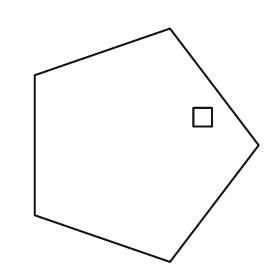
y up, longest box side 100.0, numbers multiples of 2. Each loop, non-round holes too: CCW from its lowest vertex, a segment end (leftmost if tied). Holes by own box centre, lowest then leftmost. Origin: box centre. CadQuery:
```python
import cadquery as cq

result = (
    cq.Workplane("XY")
    .moveTo(10.0, -50.0)
    .lineTo(48.0, 0.0)
    .lineTo(10.0, 50.0)
    .lineTo(-48.0, 30.0)
    .lineTo(-48.0, -30.0)
    .close()
    .moveTo(20.0, 8.0)
    .lineTo(28.0, 8.0)
    .lineTo(28.0, 16.0)
    .lineTo(20.0, 16.0)
    .close()
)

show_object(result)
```